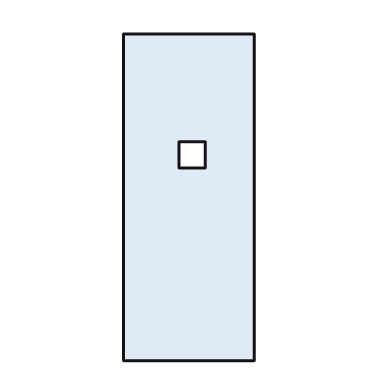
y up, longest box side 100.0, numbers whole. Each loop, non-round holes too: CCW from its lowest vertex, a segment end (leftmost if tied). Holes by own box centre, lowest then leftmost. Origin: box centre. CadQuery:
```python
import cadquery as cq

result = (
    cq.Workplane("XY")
    .moveTo(-20.0, -50.0)
    .lineTo(20.0, -50.0)
    .lineTo(20.0, 50.0)
    .lineTo(-20.0, 50.0)
    .close()
    .moveTo(-3.0, 9.0)
    .lineTo(5.0, 9.0)
    .lineTo(5.0, 17.0)
    .lineTo(-3.0, 17.0)
    .close()
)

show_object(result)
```